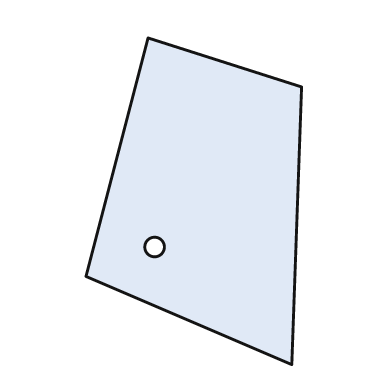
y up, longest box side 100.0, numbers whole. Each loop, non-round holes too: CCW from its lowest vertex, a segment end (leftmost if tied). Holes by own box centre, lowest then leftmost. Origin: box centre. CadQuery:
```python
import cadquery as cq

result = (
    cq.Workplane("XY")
    .moveTo(30.0, -50.0)
    .lineTo(33.0, 35.0)
    .lineTo(-14.0, 50.0)
    .lineTo(-33.0, -23.0)
    .close()
    .moveTo(-12.0, -14.0)
    .circle(3.0)
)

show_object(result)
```